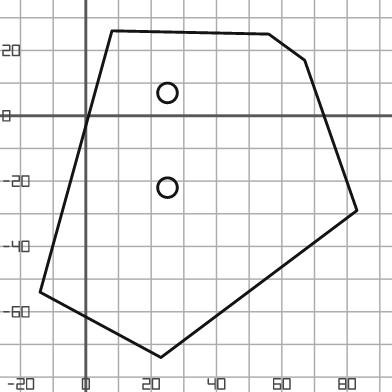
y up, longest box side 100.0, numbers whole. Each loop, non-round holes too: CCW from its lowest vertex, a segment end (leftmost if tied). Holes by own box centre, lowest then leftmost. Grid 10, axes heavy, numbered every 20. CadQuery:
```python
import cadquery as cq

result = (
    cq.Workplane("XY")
    .moveTo(23.0, -74.0)
    .lineTo(83.0, -29.0)
    .lineTo(67.0, 17.0)
    .lineTo(56.0, 25.0)
    .lineTo(8.0, 26.0)
    .lineTo(-14.0, -54.0)
    .close()
    .moveTo(25.0, -22.0)
    .circle(3.0)
    .moveTo(25.0, 7.0)
    .circle(3.0)
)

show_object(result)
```